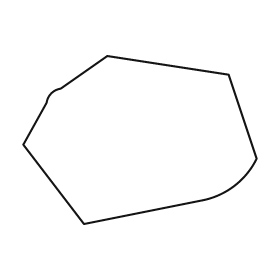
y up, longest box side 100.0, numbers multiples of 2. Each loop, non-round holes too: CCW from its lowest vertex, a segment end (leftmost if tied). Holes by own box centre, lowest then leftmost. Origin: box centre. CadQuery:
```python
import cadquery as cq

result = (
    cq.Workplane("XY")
    .moveTo(-24.0, -36.0)
    .lineTo(26.0, -26.0)
    .threePointArc((40.0, -20.0), (50.0, -8.0))
    .lineTo(38.0, 28.0)
    .lineTo(-14.0, 36.0)
    .lineTo(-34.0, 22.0)
    .threePointArc((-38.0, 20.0), (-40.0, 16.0))
    .lineTo(-50.0, -2.0)
    .close()
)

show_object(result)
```